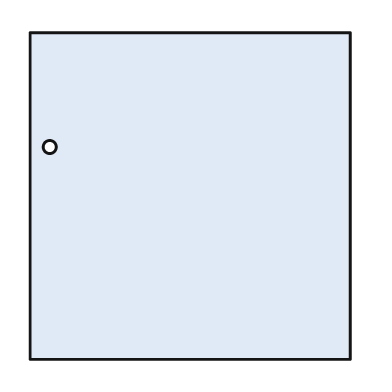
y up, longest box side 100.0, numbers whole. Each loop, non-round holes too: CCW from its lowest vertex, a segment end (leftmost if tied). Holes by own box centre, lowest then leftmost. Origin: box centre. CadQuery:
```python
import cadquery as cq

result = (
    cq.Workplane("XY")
    .moveTo(-49.0, -50.0)
    .lineTo(49.0, -50.0)
    .lineTo(49.0, 50.0)
    .lineTo(-49.0, 50.0)
    .close()
    .moveTo(-43.0, 15.0)
    .circle(2.0)
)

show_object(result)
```